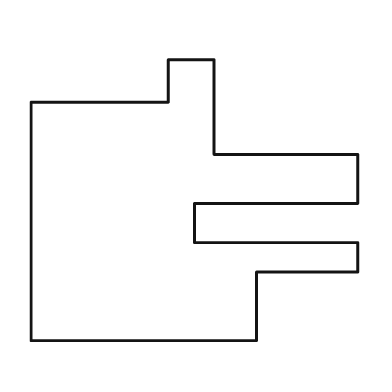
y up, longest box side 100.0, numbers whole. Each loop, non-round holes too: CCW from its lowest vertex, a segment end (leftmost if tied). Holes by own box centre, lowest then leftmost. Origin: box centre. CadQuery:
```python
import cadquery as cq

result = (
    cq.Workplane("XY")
    .moveTo(-50.0, -43.0)
    .lineTo(19.0, -43.0)
    .lineTo(19.0, -22.0)
    .lineTo(50.0, -22.0)
    .lineTo(50.0, -13.0)
    .lineTo(0.0, -13.0)
    .lineTo(0.0, -1.0)
    .lineTo(50.0, -1.0)
    .lineTo(50.0, 14.0)
    .lineTo(6.0, 14.0)
    .lineTo(6.0, 43.0)
    .lineTo(-8.0, 43.0)
    .lineTo(-8.0, 30.0)
    .lineTo(-50.0, 30.0)
    .close()
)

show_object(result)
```